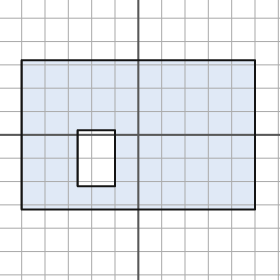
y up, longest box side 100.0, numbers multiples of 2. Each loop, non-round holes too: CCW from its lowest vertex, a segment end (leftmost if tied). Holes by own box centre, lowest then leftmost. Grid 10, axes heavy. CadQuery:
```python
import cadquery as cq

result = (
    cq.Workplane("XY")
    .moveTo(-50.0, -32.0)
    .lineTo(50.0, -32.0)
    .lineTo(50.0, 32.0)
    .lineTo(-50.0, 32.0)
    .close()
    .moveTo(-26.0, -22.0)
    .lineTo(-10.0, -22.0)
    .lineTo(-10.0, 2.0)
    .lineTo(-26.0, 2.0)
    .close()
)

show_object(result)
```